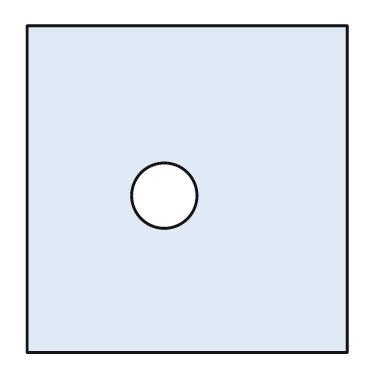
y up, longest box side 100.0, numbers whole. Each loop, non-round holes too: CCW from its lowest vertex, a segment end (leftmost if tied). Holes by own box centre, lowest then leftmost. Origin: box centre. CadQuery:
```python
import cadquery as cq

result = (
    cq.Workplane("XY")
    .moveTo(-49.0, -50.0)
    .lineTo(49.0, -50.0)
    .lineTo(49.0, 50.0)
    .lineTo(-49.0, 50.0)
    .close()
    .moveTo(-7.0, -2.0)
    .circle(10.0)
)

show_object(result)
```